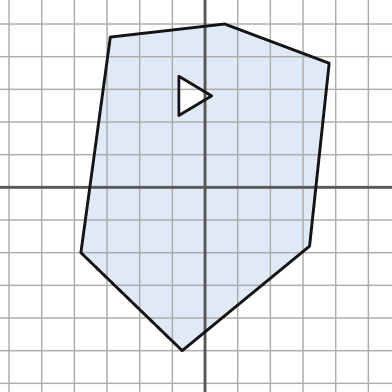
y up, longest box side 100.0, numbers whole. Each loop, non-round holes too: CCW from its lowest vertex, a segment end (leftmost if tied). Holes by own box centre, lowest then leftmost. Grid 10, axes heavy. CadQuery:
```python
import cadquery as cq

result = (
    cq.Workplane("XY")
    .moveTo(-7.0, -50.0)
    .lineTo(32.0, -18.0)
    .lineTo(38.0, 38.0)
    .lineTo(6.0, 50.0)
    .lineTo(-29.0, 46.0)
    .lineTo(-38.0, -20.0)
    .close()
    .moveTo(-8.0, 22.0)
    .lineTo(2.0, 28.0)
    .lineTo(-8.0, 34.0)
    .close()
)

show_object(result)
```